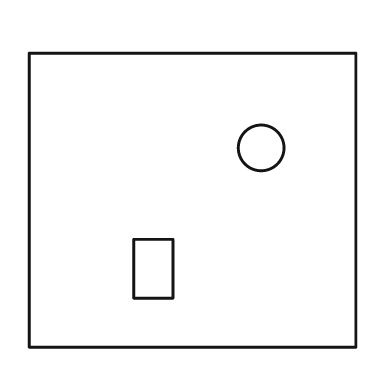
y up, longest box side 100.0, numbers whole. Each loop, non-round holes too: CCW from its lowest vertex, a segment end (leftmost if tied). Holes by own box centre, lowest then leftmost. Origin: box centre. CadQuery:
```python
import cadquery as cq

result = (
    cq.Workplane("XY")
    .moveTo(-50.0, -45.0)
    .lineTo(50.0, -45.0)
    .lineTo(50.0, 45.0)
    .lineTo(-50.0, 45.0)
    .close()
    .moveTo(-18.0, -30.0)
    .lineTo(-6.0, -30.0)
    .lineTo(-6.0, -12.0)
    .lineTo(-18.0, -12.0)
    .close()
    .moveTo(21.0, 16.0)
    .circle(7.0)
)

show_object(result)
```